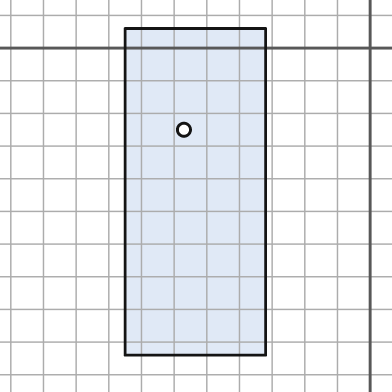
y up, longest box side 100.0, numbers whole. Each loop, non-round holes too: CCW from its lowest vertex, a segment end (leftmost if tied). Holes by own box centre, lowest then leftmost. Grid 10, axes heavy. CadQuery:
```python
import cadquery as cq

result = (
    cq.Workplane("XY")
    .moveTo(-75.0, -94.0)
    .lineTo(-32.0, -94.0)
    .lineTo(-32.0, 6.0)
    .lineTo(-75.0, 6.0)
    .close()
    .moveTo(-57.0, -25.0)
    .circle(2.0)
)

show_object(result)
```